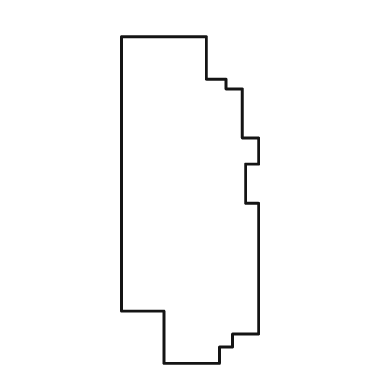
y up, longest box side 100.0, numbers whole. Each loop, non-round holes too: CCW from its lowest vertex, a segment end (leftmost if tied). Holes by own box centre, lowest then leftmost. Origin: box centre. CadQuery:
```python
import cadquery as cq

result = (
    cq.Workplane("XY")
    .moveTo(-8.0, -50.0)
    .lineTo(9.0, -50.0)
    .lineTo(9.0, -45.0)
    .lineTo(13.0, -45.0)
    .lineTo(13.0, -41.0)
    .lineTo(21.0, -41.0)
    .lineTo(21.0, -1.0)
    .lineTo(17.0, -1.0)
    .lineTo(17.0, 11.0)
    .lineTo(21.0, 11.0)
    .lineTo(21.0, 19.0)
    .lineTo(16.0, 19.0)
    .lineTo(16.0, 34.0)
    .lineTo(11.0, 34.0)
    .lineTo(11.0, 37.0)
    .lineTo(5.0, 37.0)
    .lineTo(5.0, 50.0)
    .lineTo(-21.0, 50.0)
    .lineTo(-21.0, -34.0)
    .lineTo(-8.0, -34.0)
    .close()
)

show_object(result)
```